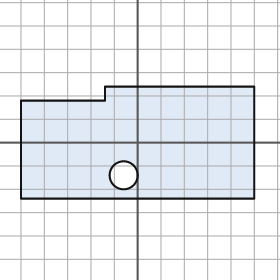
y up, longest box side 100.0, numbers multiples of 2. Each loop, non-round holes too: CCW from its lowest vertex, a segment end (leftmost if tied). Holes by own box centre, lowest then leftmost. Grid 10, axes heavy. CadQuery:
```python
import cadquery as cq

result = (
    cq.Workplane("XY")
    .moveTo(-50.0, -24.0)
    .lineTo(50.0, -24.0)
    .lineTo(50.0, 24.0)
    .lineTo(-14.0, 24.0)
    .lineTo(-14.0, 18.0)
    .lineTo(-50.0, 18.0)
    .close()
    .moveTo(-6.0, -14.0)
    .circle(6.0)
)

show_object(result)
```